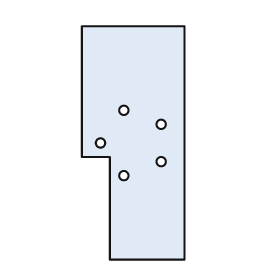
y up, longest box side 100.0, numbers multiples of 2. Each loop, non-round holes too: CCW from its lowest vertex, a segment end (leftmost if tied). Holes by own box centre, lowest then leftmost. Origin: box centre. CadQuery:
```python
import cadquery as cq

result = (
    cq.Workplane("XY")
    .moveTo(-10.0, -50.0)
    .lineTo(22.0, -50.0)
    .lineTo(22.0, 50.0)
    .lineTo(-22.0, 50.0)
    .lineTo(-22.0, -6.0)
    .lineTo(-10.0, -6.0)
    .close()
    .moveTo(-4.0, -14.0)
    .circle(2.0)
    .moveTo(12.0, -8.0)
    .circle(2.0)
    .moveTo(-14.0, 0.0)
    .circle(2.0)
    .moveTo(12.0, 8.0)
    .circle(2.0)
    .moveTo(-4.0, 14.0)
    .circle(2.0)
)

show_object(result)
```